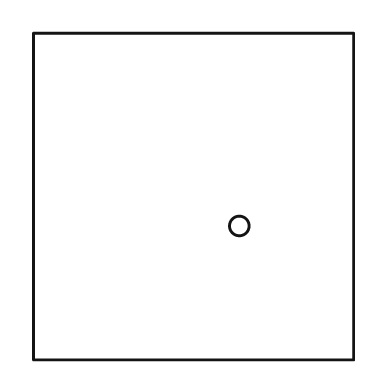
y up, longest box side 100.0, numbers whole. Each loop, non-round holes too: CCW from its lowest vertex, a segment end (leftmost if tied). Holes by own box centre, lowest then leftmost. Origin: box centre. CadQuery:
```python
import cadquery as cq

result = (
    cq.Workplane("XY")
    .moveTo(-49.0, -50.0)
    .lineTo(49.0, -50.0)
    .lineTo(49.0, 50.0)
    .lineTo(-49.0, 50.0)
    .close()
    .moveTo(14.0, -9.0)
    .circle(3.0)
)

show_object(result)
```